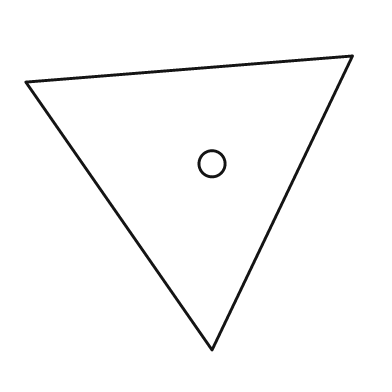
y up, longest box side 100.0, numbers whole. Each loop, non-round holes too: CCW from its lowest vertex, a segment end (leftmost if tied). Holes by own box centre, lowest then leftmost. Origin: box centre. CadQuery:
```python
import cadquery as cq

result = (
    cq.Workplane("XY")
    .moveTo(7.0, -45.0)
    .lineTo(50.0, 45.0)
    .lineTo(-50.0, 37.0)
    .close()
    .moveTo(7.0, 12.0)
    .circle(4.0)
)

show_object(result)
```